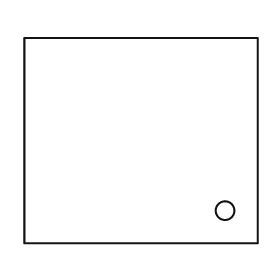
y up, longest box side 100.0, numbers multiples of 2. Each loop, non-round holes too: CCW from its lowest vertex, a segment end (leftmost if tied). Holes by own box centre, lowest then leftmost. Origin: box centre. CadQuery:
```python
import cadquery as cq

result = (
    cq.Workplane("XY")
    .moveTo(-50.0, -44.0)
    .lineTo(50.0, -44.0)
    .lineTo(50.0, 44.0)
    .lineTo(-50.0, 44.0)
    .close()
    .moveTo(36.0, -30.0)
    .circle(4.0)
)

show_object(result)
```